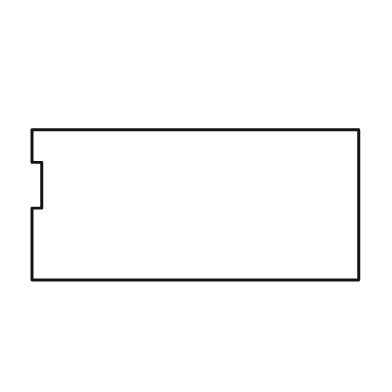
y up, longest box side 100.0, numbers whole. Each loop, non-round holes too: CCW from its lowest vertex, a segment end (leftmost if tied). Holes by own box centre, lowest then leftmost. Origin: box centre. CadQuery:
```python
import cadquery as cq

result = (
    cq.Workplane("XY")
    .moveTo(-50.0, -23.0)
    .lineTo(50.0, -23.0)
    .lineTo(50.0, 23.0)
    .lineTo(-50.0, 23.0)
    .lineTo(-50.0, 13.0)
    .lineTo(-47.0, 13.0)
    .lineTo(-47.0, -1.0)
    .lineTo(-50.0, -1.0)
    .close()
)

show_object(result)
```